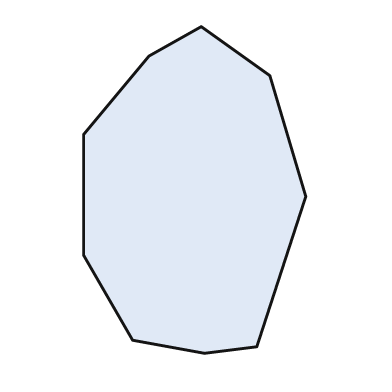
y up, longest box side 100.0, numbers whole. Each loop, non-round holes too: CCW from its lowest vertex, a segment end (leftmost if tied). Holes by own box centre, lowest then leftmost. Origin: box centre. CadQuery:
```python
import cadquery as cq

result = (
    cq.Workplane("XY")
    .moveTo(3.0, -50.0)
    .lineTo(19.0, -48.0)
    .lineTo(34.0, -2.0)
    .lineTo(23.0, 35.0)
    .lineTo(2.0, 50.0)
    .lineTo(-14.0, 41.0)
    .lineTo(-34.0, 17.0)
    .lineTo(-34.0, -20.0)
    .lineTo(-19.0, -46.0)
    .close()
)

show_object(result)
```